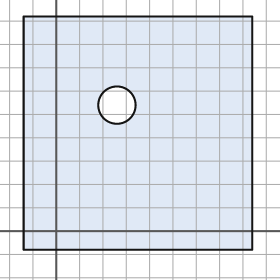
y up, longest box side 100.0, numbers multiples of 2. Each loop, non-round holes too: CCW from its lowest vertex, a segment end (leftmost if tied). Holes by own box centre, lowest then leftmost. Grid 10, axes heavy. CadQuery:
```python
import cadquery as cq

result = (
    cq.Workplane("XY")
    .moveTo(-14.0, -8.0)
    .lineTo(84.0, -8.0)
    .lineTo(84.0, 92.0)
    .lineTo(-14.0, 92.0)
    .close()
    .moveTo(26.0, 54.0)
    .circle(8.0)
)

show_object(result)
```